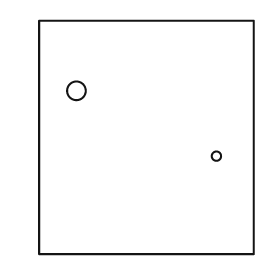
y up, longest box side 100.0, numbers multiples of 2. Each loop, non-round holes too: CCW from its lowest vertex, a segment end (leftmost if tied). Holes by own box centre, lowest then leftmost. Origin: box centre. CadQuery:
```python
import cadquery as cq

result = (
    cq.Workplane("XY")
    .moveTo(-46.0, -50.0)
    .lineTo(46.0, -50.0)
    .lineTo(46.0, 50.0)
    .lineTo(-46.0, 50.0)
    .close()
    .moveTo(30.0, -8.0)
    .circle(2.0)
    .moveTo(-30.0, 20.0)
    .circle(4.0)
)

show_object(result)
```